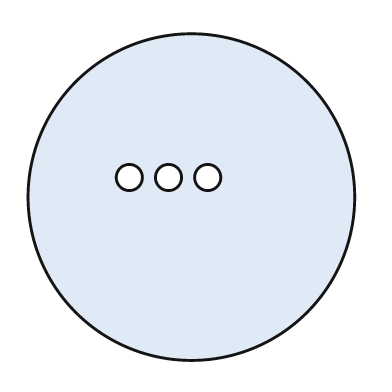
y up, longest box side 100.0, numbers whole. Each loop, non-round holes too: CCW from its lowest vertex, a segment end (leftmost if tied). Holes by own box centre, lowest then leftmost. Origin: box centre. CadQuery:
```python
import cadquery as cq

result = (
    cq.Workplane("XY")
    .moveTo(0.0, 0.0)
    .circle(50.0)
    .moveTo(-19.0, 6.0)
    .circle(4.0)
    .moveTo(-7.0, 6.0)
    .circle(4.0)
    .moveTo(5.0, 6.0)
    .circle(4.0)
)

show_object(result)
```